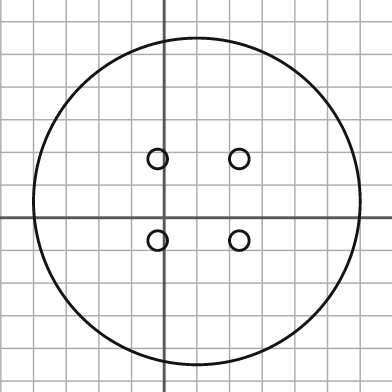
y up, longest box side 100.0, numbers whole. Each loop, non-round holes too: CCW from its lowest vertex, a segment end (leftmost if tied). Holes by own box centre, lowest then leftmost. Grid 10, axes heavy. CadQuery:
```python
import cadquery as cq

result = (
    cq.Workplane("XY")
    .moveTo(10.0, 5.0)
    .circle(50.0)
    .moveTo(-2.0, -7.0)
    .circle(3.0)
    .moveTo(23.0, -7.0)
    .circle(3.0)
    .moveTo(-2.0, 18.0)
    .circle(3.0)
    .moveTo(23.0, 18.0)
    .circle(3.0)
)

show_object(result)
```